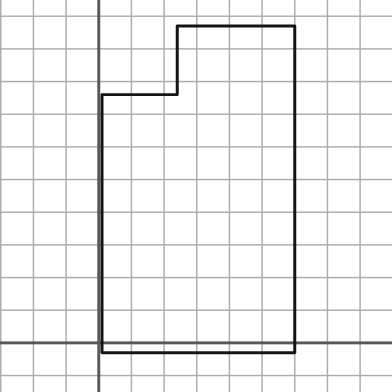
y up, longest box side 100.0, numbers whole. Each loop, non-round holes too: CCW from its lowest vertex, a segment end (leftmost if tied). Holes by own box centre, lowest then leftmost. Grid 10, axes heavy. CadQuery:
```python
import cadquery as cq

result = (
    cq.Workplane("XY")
    .moveTo(1.0, -3.0)
    .lineTo(60.0, -3.0)
    .lineTo(60.0, 97.0)
    .lineTo(24.0, 97.0)
    .lineTo(24.0, 76.0)
    .lineTo(1.0, 76.0)
    .close()
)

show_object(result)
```